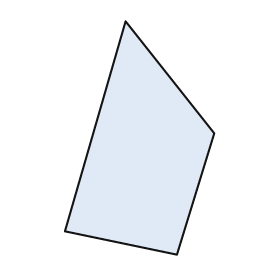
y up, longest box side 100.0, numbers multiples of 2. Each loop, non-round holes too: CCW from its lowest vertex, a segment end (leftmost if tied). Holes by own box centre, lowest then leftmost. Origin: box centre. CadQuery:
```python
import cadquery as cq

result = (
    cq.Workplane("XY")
    .moveTo(16.0, -50.0)
    .lineTo(32.0, 2.0)
    .lineTo(-6.0, 50.0)
    .lineTo(-32.0, -40.0)
    .close()
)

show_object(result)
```